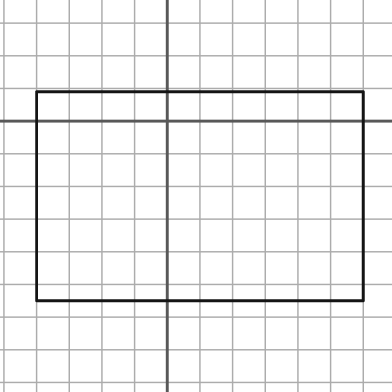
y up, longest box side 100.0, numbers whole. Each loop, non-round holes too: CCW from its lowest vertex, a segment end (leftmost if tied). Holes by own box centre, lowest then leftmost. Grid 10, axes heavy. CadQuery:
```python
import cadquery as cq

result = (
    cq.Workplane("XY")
    .moveTo(-40.0, -55.0)
    .lineTo(60.0, -55.0)
    .lineTo(60.0, 9.0)
    .lineTo(-40.0, 9.0)
    .close()
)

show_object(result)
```